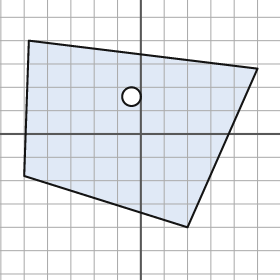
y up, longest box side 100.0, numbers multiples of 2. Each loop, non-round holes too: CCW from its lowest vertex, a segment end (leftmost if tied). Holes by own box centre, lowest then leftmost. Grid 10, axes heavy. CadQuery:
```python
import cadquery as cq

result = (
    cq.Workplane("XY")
    .moveTo(20.0, -40.0)
    .lineTo(50.0, 28.0)
    .lineTo(-48.0, 40.0)
    .lineTo(-50.0, -18.0)
    .close()
    .moveTo(-4.0, 16.0)
    .circle(4.0)
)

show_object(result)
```